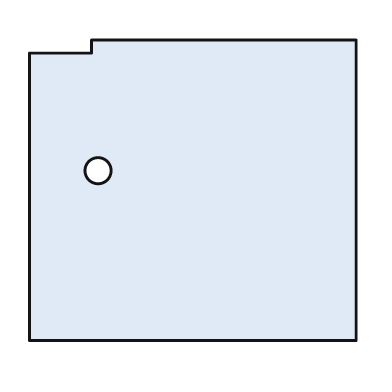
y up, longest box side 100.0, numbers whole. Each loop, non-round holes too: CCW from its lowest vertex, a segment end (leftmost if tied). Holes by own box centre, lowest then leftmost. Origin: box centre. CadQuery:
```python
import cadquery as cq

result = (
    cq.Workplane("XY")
    .moveTo(-50.0, -46.0)
    .lineTo(50.0, -46.0)
    .lineTo(50.0, 46.0)
    .lineTo(-31.0, 46.0)
    .lineTo(-31.0, 42.0)
    .lineTo(-50.0, 42.0)
    .close()
    .moveTo(-29.0, 6.0)
    .circle(4.0)
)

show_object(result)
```